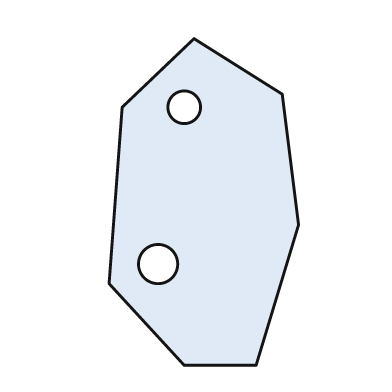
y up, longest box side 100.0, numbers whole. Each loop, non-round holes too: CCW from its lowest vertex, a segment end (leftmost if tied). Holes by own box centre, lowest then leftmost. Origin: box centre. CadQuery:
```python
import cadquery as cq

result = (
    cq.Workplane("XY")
    .moveTo(-6.0, -50.0)
    .lineTo(16.0, -50.0)
    .lineTo(29.0, -7.0)
    .lineTo(24.0, 33.0)
    .lineTo(-3.0, 50.0)
    .lineTo(-25.0, 29.0)
    .lineTo(-29.0, -25.0)
    .close()
    .moveTo(-14.0, -19.0)
    .circle(6.0)
    .moveTo(-6.0, 29.0)
    .circle(5.0)
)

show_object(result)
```